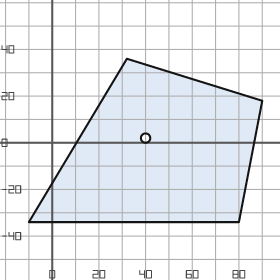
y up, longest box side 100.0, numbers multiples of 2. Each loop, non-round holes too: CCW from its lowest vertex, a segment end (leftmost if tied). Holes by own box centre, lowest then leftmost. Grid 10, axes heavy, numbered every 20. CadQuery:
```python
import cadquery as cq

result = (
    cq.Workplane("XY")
    .moveTo(-10.0, -34.0)
    .lineTo(80.0, -34.0)
    .lineTo(90.0, 18.0)
    .lineTo(32.0, 36.0)
    .close()
    .moveTo(40.0, 2.0)
    .circle(2.0)
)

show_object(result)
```